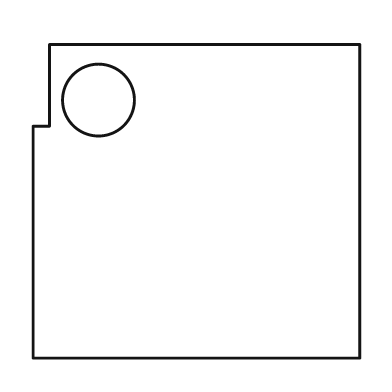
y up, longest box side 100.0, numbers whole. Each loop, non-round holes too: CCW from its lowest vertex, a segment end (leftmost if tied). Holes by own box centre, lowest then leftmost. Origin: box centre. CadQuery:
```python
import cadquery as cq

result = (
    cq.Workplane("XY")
    .moveTo(-50.0, -48.0)
    .lineTo(50.0, -48.0)
    .lineTo(50.0, 48.0)
    .lineTo(-45.0, 48.0)
    .lineTo(-45.0, 23.0)
    .lineTo(-50.0, 23.0)
    .close()
    .moveTo(-30.0, 31.0)
    .circle(11.0)
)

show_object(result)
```